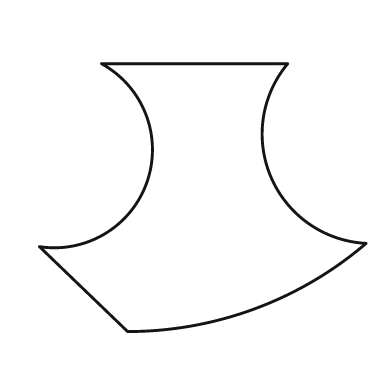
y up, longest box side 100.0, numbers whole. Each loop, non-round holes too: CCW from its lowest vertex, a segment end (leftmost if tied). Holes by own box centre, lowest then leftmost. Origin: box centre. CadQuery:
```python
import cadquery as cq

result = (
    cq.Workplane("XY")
    .moveTo(-23.0, -41.0)
    .threePointArc((16.0, -34.0), (50.0, -14.0))
    .threePointArc((21.0, 6.0), (26.0, 41.0))
    .lineTo(-31.0, 41.0)
    .threePointArc((-17.0, 5.0), (-50.0, -15.0))
    .close()
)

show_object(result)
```